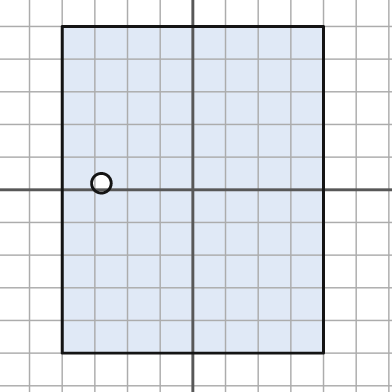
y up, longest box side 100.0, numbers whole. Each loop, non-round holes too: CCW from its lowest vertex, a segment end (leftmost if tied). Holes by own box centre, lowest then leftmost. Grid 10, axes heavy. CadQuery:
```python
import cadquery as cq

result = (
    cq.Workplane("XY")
    .moveTo(-40.0, -50.0)
    .lineTo(40.0, -50.0)
    .lineTo(40.0, 50.0)
    .lineTo(-40.0, 50.0)
    .close()
    .moveTo(-28.0, 2.0)
    .circle(3.0)
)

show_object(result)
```